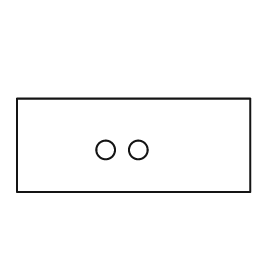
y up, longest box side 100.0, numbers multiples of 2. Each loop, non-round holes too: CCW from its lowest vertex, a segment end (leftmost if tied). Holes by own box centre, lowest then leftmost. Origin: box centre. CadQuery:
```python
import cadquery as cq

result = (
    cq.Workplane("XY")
    .moveTo(-50.0, -20.0)
    .lineTo(50.0, -20.0)
    .lineTo(50.0, 20.0)
    .lineTo(-50.0, 20.0)
    .close()
    .moveTo(-12.0, -2.0)
    .circle(4.0)
    .moveTo(2.0, -2.0)
    .circle(4.0)
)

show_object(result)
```